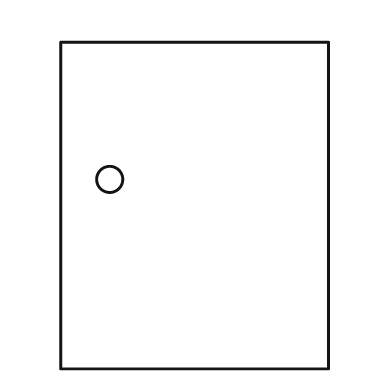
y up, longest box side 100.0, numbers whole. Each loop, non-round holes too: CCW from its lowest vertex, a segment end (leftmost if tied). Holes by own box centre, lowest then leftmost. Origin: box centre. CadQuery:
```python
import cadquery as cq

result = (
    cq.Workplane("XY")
    .moveTo(-41.0, -50.0)
    .lineTo(41.0, -50.0)
    .lineTo(41.0, 50.0)
    .lineTo(-41.0, 50.0)
    .close()
    .moveTo(-26.0, 8.0)
    .circle(4.0)
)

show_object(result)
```